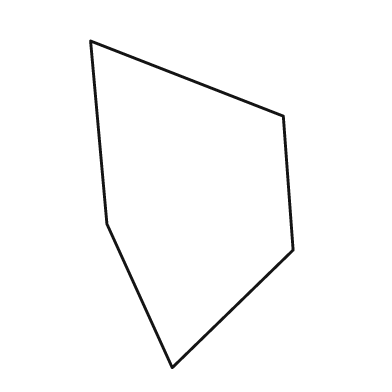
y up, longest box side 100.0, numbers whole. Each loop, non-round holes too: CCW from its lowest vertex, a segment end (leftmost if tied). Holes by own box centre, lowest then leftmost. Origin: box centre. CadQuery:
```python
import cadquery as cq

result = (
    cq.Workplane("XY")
    .moveTo(-6.0, -50.0)
    .lineTo(31.0, -14.0)
    .lineTo(28.0, 27.0)
    .lineTo(-31.0, 50.0)
    .lineTo(-26.0, -6.0)
    .close()
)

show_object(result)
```